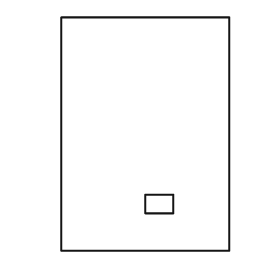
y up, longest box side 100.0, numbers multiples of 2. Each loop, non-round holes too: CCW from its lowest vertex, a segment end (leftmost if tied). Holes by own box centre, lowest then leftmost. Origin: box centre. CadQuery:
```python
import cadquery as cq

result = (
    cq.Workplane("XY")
    .moveTo(-36.0, -50.0)
    .lineTo(36.0, -50.0)
    .lineTo(36.0, 50.0)
    .lineTo(-36.0, 50.0)
    .close()
    .moveTo(0.0, -34.0)
    .lineTo(12.0, -34.0)
    .lineTo(12.0, -26.0)
    .lineTo(0.0, -26.0)
    .close()
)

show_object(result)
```